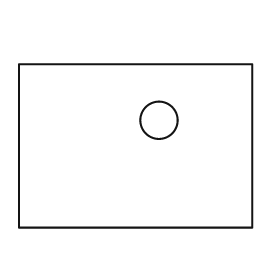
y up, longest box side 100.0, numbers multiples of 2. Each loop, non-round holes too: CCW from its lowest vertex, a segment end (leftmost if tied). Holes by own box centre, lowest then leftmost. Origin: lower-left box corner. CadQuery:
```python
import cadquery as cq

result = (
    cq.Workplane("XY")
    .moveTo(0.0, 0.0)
    .lineTo(100.0, 0.0)
    .lineTo(100.0, 70.0)
    .lineTo(0.0, 70.0)
    .close()
    .moveTo(60.0, 46.0)
    .circle(8.0)
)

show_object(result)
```